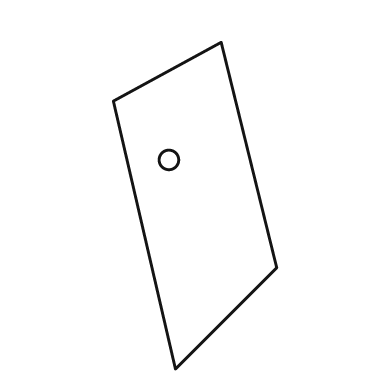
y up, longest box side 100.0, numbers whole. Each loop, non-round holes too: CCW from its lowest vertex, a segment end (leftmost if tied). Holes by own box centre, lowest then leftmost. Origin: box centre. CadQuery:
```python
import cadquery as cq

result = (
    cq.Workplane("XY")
    .moveTo(-6.0, -50.0)
    .lineTo(25.0, -19.0)
    .lineTo(8.0, 50.0)
    .lineTo(-25.0, 32.0)
    .close()
    .moveTo(-8.0, 14.0)
    .circle(3.0)
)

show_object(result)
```